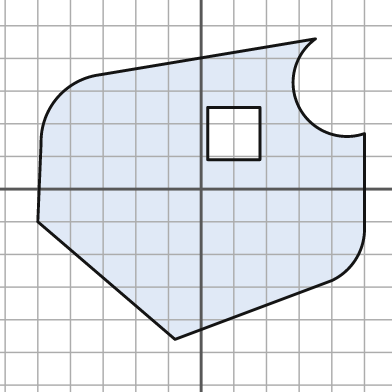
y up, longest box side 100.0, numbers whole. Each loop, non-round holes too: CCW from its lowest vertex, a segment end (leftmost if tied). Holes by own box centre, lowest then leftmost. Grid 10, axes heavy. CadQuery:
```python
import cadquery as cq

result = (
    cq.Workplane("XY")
    .moveTo(-8.0, -46.0)
    .lineTo(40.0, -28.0)
    .threePointArc((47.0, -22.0), (50.0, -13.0))
    .lineTo(50.0, 17.0)
    .threePointArc((30.0, 25.0), (35.0, 46.0))
    .lineTo(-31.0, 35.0)
    .threePointArc((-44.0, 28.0), (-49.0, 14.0))
    .lineTo(-50.0, -10.0)
    .close()
    .moveTo(2.0, 9.0)
    .lineTo(18.0, 9.0)
    .lineTo(18.0, 25.0)
    .lineTo(2.0, 25.0)
    .close()
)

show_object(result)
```